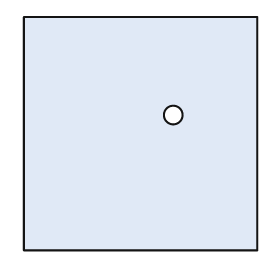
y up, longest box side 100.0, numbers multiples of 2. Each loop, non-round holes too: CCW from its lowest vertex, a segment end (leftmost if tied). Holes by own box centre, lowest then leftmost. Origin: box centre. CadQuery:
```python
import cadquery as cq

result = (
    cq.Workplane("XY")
    .moveTo(-50.0, -50.0)
    .lineTo(50.0, -50.0)
    .lineTo(50.0, 50.0)
    .lineTo(-50.0, 50.0)
    .close()
    .moveTo(14.0, 8.0)
    .circle(4.0)
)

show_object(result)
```